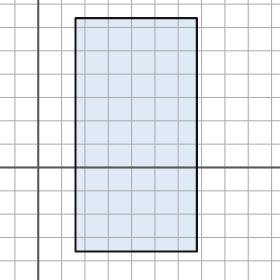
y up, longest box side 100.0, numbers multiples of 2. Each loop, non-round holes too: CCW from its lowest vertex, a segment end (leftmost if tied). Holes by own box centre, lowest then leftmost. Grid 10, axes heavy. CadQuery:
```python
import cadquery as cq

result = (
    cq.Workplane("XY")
    .moveTo(16.0, -36.0)
    .lineTo(68.0, -36.0)
    .lineTo(68.0, 64.0)
    .lineTo(16.0, 64.0)
    .close()
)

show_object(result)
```